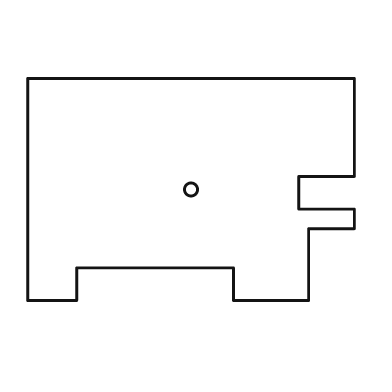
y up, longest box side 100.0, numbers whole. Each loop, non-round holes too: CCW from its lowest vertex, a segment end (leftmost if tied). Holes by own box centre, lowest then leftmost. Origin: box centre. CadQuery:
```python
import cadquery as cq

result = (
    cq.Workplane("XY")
    .moveTo(-50.0, -34.0)
    .lineTo(-35.0, -34.0)
    .lineTo(-35.0, -24.0)
    .lineTo(13.0, -24.0)
    .lineTo(13.0, -34.0)
    .lineTo(36.0, -34.0)
    .lineTo(36.0, -12.0)
    .lineTo(50.0, -12.0)
    .lineTo(50.0, -6.0)
    .lineTo(33.0, -6.0)
    .lineTo(33.0, 4.0)
    .lineTo(50.0, 4.0)
    .lineTo(50.0, 34.0)
    .lineTo(-50.0, 34.0)
    .close()
    .moveTo(0.0, 0.0)
    .circle(2.0)
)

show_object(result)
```